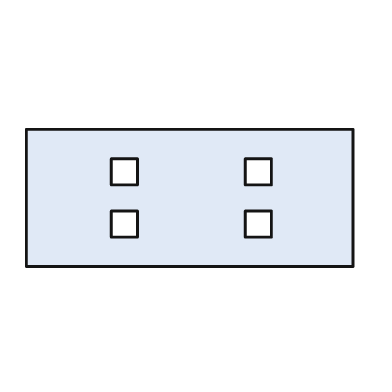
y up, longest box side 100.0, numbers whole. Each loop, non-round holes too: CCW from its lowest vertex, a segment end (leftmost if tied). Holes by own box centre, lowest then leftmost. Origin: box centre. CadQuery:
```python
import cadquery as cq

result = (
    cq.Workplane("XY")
    .moveTo(-50.0, -21.0)
    .lineTo(50.0, -21.0)
    .lineTo(50.0, 21.0)
    .lineTo(-50.0, 21.0)
    .close()
    .moveTo(-24.0, -12.0)
    .lineTo(-16.0, -12.0)
    .lineTo(-16.0, -4.0)
    .lineTo(-24.0, -4.0)
    .close()
    .moveTo(17.0, -12.0)
    .lineTo(25.0, -12.0)
    .lineTo(25.0, -4.0)
    .lineTo(17.0, -4.0)
    .close()
    .moveTo(-24.0, 4.0)
    .lineTo(-16.0, 4.0)
    .lineTo(-16.0, 12.0)
    .lineTo(-24.0, 12.0)
    .close()
    .moveTo(17.0, 4.0)
    .lineTo(25.0, 4.0)
    .lineTo(25.0, 12.0)
    .lineTo(17.0, 12.0)
    .close()
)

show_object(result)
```